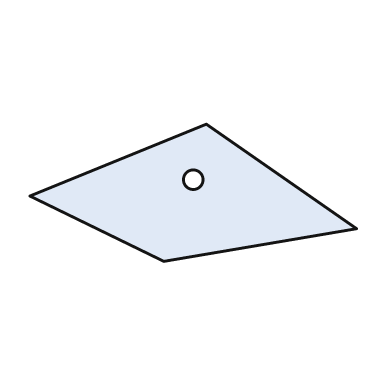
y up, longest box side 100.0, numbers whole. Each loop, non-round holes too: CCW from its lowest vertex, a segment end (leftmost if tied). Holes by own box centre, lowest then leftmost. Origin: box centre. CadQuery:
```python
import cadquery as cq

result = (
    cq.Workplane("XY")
    .moveTo(-9.0, -21.0)
    .lineTo(50.0, -11.0)
    .lineTo(4.0, 21.0)
    .lineTo(-50.0, -1.0)
    .close()
    .moveTo(0.0, 4.0)
    .circle(3.0)
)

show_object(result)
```